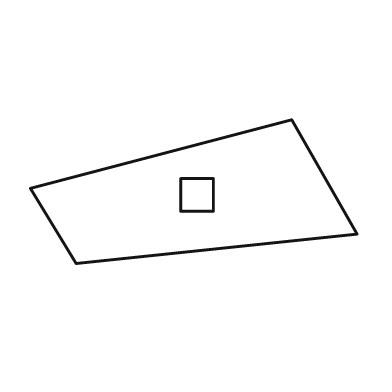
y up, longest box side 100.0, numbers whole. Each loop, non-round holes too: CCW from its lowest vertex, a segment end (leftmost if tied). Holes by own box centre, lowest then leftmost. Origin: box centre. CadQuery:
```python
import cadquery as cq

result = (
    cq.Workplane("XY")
    .moveTo(-36.0, -22.0)
    .lineTo(50.0, -13.0)
    .lineTo(30.0, 22.0)
    .lineTo(-50.0, 1.0)
    .close()
    .moveTo(-4.0, -6.0)
    .lineTo(6.0, -6.0)
    .lineTo(6.0, 4.0)
    .lineTo(-4.0, 4.0)
    .close()
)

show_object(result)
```